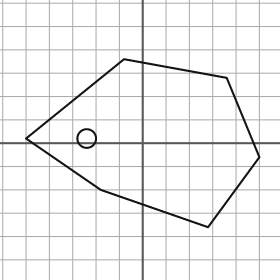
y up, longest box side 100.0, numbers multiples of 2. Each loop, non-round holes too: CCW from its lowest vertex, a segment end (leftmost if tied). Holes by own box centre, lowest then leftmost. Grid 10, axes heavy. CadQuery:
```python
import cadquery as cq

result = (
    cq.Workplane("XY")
    .moveTo(28.0, -36.0)
    .lineTo(50.0, -6.0)
    .lineTo(36.0, 28.0)
    .lineTo(-8.0, 36.0)
    .lineTo(-50.0, 2.0)
    .lineTo(-18.0, -20.0)
    .close()
    .moveTo(-24.0, 2.0)
    .circle(4.0)
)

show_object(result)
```